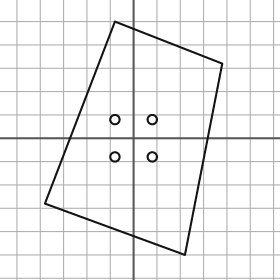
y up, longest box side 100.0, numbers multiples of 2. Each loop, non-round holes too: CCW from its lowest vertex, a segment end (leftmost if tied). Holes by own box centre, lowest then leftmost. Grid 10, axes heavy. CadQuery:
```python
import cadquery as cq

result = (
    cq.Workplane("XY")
    .moveTo(22.0, -50.0)
    .lineTo(38.0, 32.0)
    .lineTo(-8.0, 50.0)
    .lineTo(-38.0, -28.0)
    .close()
    .moveTo(-8.0, -8.0)
    .circle(2.0)
    .moveTo(8.0, -8.0)
    .circle(2.0)
    .moveTo(-8.0, 8.0)
    .circle(2.0)
    .moveTo(8.0, 8.0)
    .circle(2.0)
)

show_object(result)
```